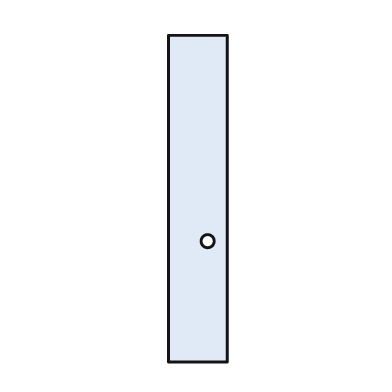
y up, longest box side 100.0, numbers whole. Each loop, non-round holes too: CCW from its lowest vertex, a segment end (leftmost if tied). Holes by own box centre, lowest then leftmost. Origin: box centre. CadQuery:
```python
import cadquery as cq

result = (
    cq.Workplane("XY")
    .moveTo(-9.0, -50.0)
    .lineTo(9.0, -50.0)
    .lineTo(9.0, 50.0)
    .lineTo(-9.0, 50.0)
    .close()
    .moveTo(3.0, -13.0)
    .circle(2.0)
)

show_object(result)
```